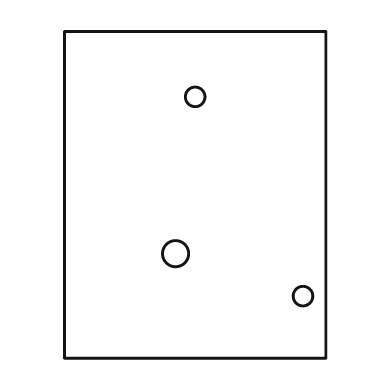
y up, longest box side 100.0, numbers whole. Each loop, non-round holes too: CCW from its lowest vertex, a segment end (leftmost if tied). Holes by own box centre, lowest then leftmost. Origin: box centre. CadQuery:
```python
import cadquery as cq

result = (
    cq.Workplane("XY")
    .moveTo(-40.0, -50.0)
    .lineTo(40.0, -50.0)
    .lineTo(40.0, 50.0)
    .lineTo(-40.0, 50.0)
    .close()
    .moveTo(33.0, -31.0)
    .circle(3.0)
    .moveTo(-6.0, -18.0)
    .circle(4.0)
    .moveTo(0.0, 30.0)
    .circle(3.0)
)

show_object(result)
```